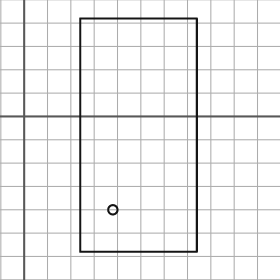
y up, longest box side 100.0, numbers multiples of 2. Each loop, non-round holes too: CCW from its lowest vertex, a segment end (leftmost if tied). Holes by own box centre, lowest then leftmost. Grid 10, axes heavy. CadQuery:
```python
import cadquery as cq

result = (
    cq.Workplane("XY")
    .moveTo(24.0, -58.0)
    .lineTo(74.0, -58.0)
    .lineTo(74.0, 42.0)
    .lineTo(24.0, 42.0)
    .close()
    .moveTo(38.0, -40.0)
    .circle(2.0)
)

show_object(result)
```